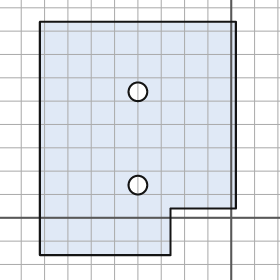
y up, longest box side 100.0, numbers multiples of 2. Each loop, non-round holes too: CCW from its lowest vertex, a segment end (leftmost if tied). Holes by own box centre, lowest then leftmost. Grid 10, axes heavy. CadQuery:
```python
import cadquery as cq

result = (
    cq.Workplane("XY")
    .moveTo(-82.0, -16.0)
    .lineTo(-26.0, -16.0)
    .lineTo(-26.0, 4.0)
    .lineTo(2.0, 4.0)
    .lineTo(2.0, 84.0)
    .lineTo(-82.0, 84.0)
    .close()
    .moveTo(-40.0, 14.0)
    .circle(4.0)
    .moveTo(-40.0, 54.0)
    .circle(4.0)
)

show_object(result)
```